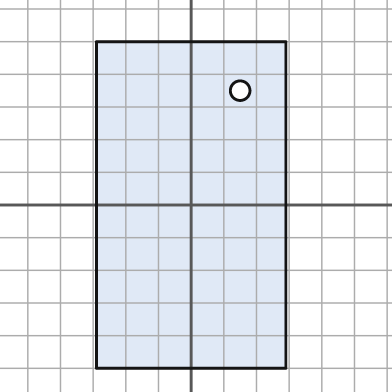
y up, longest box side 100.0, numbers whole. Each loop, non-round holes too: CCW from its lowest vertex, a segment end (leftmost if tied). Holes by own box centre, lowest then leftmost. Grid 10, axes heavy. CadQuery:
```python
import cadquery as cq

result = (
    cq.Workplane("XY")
    .moveTo(-29.0, -50.0)
    .lineTo(29.0, -50.0)
    .lineTo(29.0, 50.0)
    .lineTo(-29.0, 50.0)
    .close()
    .moveTo(15.0, 35.0)
    .circle(3.0)
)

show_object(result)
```